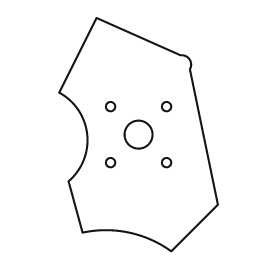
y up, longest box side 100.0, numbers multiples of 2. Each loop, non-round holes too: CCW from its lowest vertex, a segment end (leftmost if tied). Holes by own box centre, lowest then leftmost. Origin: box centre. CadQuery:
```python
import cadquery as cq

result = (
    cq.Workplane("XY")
    .moveTo(14.0, -50.0)
    .lineTo(34.0, -30.0)
    .lineTo(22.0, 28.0)
    .threePointArc((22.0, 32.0), (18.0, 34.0))
    .lineTo(-18.0, 50.0)
    .lineTo(-34.0, 18.0)
    .threePointArc((-22.0, 0.0), (-30.0, -20.0))
    .lineTo(-24.0, -42.0)
    .threePointArc((-4.0, -42.0), (14.0, -50.0))
    .close()
    .moveTo(-12.0, -12.0)
    .circle(2.0)
    .moveTo(12.0, -12.0)
    .circle(2.0)
    .moveTo(0.0, 0.0)
    .circle(6.0)
    .moveTo(-12.0, 12.0)
    .circle(2.0)
    .moveTo(12.0, 12.0)
    .circle(2.0)
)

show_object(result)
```